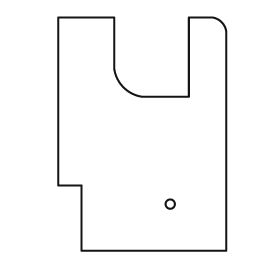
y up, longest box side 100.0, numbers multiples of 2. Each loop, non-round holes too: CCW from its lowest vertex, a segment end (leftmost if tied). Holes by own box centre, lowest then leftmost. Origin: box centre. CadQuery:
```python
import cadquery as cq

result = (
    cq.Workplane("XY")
    .moveTo(-26.0, -50.0)
    .lineTo(36.0, -50.0)
    .lineTo(36.0, 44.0)
    .threePointArc((34.0, 48.0), (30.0, 50.0))
    .lineTo(20.0, 50.0)
    .lineTo(20.0, 16.0)
    .lineTo(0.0, 16.0)
    .threePointArc((-8.0, 20.0), (-12.0, 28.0))
    .lineTo(-12.0, 50.0)
    .lineTo(-36.0, 50.0)
    .lineTo(-36.0, -22.0)
    .lineTo(-26.0, -22.0)
    .close()
    .moveTo(12.0, -30.0)
    .circle(2.0)
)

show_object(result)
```